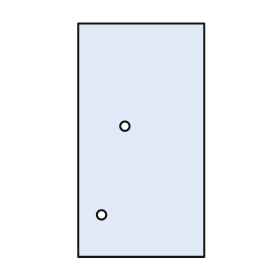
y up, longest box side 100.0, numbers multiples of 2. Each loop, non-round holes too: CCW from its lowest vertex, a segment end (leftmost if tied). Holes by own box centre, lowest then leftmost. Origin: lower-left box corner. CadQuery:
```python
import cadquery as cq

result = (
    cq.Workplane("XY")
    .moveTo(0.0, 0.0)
    .lineTo(54.0, 0.0)
    .lineTo(54.0, 100.0)
    .lineTo(0.0, 100.0)
    .close()
    .moveTo(10.0, 18.0)
    .circle(2.0)
    .moveTo(20.0, 56.0)
    .circle(2.0)
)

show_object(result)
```